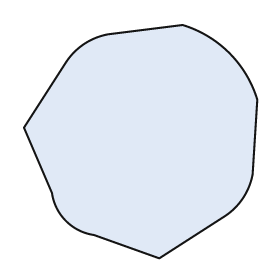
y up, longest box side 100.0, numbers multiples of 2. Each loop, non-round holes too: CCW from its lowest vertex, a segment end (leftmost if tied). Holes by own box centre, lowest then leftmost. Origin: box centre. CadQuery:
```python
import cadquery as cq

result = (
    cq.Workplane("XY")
    .moveTo(8.0, -50.0)
    .lineTo(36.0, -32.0)
    .threePointArc((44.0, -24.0), (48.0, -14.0))
    .lineTo(50.0, 18.0)
    .threePointArc((38.0, 38.0), (18.0, 50.0))
    .lineTo(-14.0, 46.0)
    .threePointArc((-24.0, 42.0), (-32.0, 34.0))
    .lineTo(-50.0, 6.0)
    .lineTo(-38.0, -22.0)
    .threePointArc((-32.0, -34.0), (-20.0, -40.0))
    .close()
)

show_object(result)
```